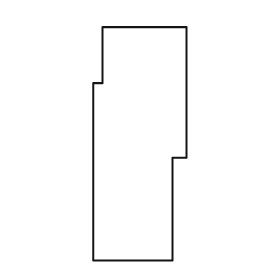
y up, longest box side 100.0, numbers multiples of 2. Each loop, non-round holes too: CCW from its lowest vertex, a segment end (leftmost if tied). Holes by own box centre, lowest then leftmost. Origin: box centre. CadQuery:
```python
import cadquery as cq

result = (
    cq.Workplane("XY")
    .moveTo(-20.0, -50.0)
    .lineTo(14.0, -50.0)
    .lineTo(14.0, -6.0)
    .lineTo(20.0, -6.0)
    .lineTo(20.0, 50.0)
    .lineTo(-16.0, 50.0)
    .lineTo(-16.0, 26.0)
    .lineTo(-20.0, 26.0)
    .close()
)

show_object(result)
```